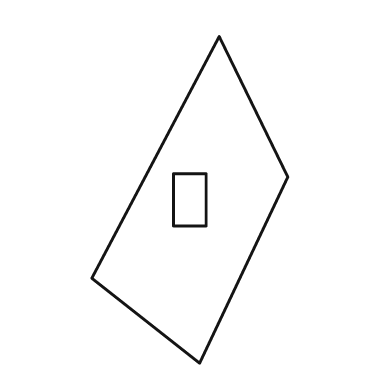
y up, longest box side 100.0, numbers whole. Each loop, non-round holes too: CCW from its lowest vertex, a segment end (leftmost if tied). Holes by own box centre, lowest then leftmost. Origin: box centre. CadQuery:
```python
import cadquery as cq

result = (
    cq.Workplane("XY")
    .moveTo(3.0, -50.0)
    .lineTo(30.0, 7.0)
    .lineTo(9.0, 50.0)
    .lineTo(-30.0, -24.0)
    .close()
    .moveTo(-5.0, -8.0)
    .lineTo(5.0, -8.0)
    .lineTo(5.0, 8.0)
    .lineTo(-5.0, 8.0)
    .close()
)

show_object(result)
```